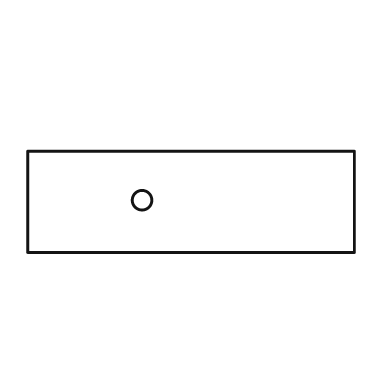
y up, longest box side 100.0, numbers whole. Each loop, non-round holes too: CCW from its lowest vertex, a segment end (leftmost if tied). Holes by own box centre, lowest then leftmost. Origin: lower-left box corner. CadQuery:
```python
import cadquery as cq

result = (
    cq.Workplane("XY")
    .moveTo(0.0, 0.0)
    .lineTo(100.0, 0.0)
    .lineTo(100.0, 31.0)
    .lineTo(0.0, 31.0)
    .close()
    .moveTo(35.0, 16.0)
    .circle(3.0)
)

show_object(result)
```